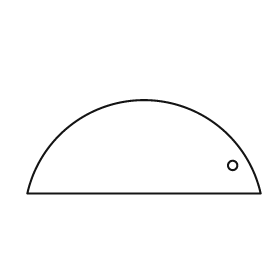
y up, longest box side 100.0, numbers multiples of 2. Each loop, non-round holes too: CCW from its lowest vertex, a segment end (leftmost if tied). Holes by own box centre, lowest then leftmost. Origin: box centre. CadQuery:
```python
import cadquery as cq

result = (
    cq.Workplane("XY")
    .moveTo(-50.0, -20.0)
    .lineTo(50.0, -20.0)
    .threePointArc((0.0, 20.0), (-50.0, -20.0))
    .close()
    .moveTo(38.0, -8.0)
    .circle(2.0)
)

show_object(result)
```